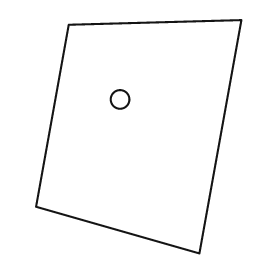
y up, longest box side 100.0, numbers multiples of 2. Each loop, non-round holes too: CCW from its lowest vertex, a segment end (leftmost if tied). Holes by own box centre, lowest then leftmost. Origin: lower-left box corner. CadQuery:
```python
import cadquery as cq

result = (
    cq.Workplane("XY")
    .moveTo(70.0, 0.0)
    .lineTo(88.0, 100.0)
    .lineTo(14.0, 98.0)
    .lineTo(0.0, 20.0)
    .close()
    .moveTo(36.0, 66.0)
    .circle(4.0)
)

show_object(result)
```